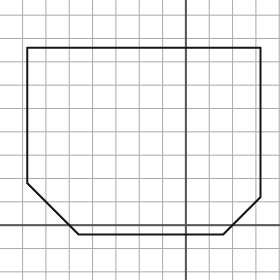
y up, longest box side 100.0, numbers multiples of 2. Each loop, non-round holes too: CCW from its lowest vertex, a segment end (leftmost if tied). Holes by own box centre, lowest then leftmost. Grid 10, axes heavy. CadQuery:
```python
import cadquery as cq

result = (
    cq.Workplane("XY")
    .moveTo(-46.0, -4.0)
    .lineTo(16.0, -4.0)
    .lineTo(32.0, 12.0)
    .lineTo(32.0, 76.0)
    .lineTo(-68.0, 76.0)
    .lineTo(-68.0, 18.0)
    .close()
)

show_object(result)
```